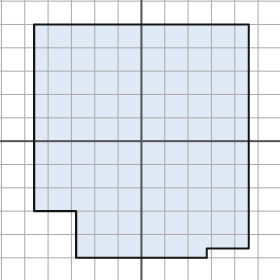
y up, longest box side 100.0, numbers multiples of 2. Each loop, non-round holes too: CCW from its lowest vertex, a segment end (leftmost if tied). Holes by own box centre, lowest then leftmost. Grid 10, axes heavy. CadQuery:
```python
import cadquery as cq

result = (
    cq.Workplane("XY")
    .moveTo(-28.0, -50.0)
    .lineTo(28.0, -50.0)
    .lineTo(28.0, -46.0)
    .lineTo(46.0, -46.0)
    .lineTo(46.0, 50.0)
    .lineTo(-46.0, 50.0)
    .lineTo(-46.0, -30.0)
    .lineTo(-28.0, -30.0)
    .close()
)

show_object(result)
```